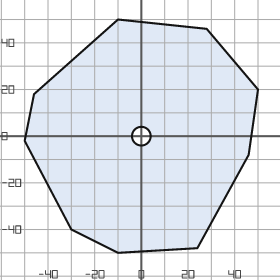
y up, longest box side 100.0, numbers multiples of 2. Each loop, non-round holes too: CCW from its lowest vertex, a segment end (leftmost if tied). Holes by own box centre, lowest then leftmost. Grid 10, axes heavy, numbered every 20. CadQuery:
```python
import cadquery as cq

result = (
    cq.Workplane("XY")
    .moveTo(-10.0, -50.0)
    .lineTo(24.0, -48.0)
    .lineTo(46.0, -8.0)
    .lineTo(50.0, 20.0)
    .lineTo(28.0, 46.0)
    .lineTo(-10.0, 50.0)
    .lineTo(-46.0, 18.0)
    .lineTo(-50.0, -2.0)
    .lineTo(-30.0, -40.0)
    .close()
    .moveTo(0.0, 0.0)
    .circle(4.0)
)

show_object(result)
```